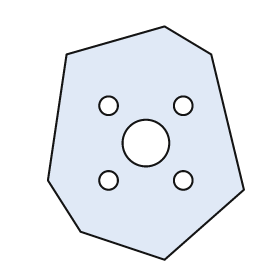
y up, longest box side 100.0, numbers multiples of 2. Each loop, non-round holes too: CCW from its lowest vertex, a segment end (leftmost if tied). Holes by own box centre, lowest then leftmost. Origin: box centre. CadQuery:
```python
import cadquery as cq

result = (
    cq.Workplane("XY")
    .moveTo(8.0, -50.0)
    .lineTo(42.0, -20.0)
    .lineTo(28.0, 38.0)
    .lineTo(8.0, 50.0)
    .lineTo(-34.0, 38.0)
    .lineTo(-42.0, -16.0)
    .lineTo(-28.0, -38.0)
    .close()
    .moveTo(-16.0, -16.0)
    .circle(4.0)
    .moveTo(16.0, -16.0)
    .circle(4.0)
    .moveTo(0.0, 0.0)
    .circle(10.0)
    .moveTo(-16.0, 16.0)
    .circle(4.0)
    .moveTo(16.0, 16.0)
    .circle(4.0)
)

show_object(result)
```